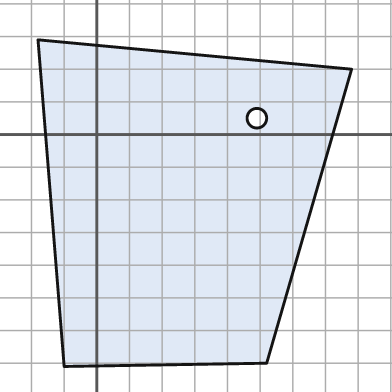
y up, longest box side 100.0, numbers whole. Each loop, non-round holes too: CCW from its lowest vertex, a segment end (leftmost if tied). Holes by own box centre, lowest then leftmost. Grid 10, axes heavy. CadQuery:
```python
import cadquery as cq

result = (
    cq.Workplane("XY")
    .moveTo(-10.0, -71.0)
    .lineTo(52.0, -70.0)
    .lineTo(78.0, 20.0)
    .lineTo(-18.0, 29.0)
    .close()
    .moveTo(49.0, 5.0)
    .circle(3.0)
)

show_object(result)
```